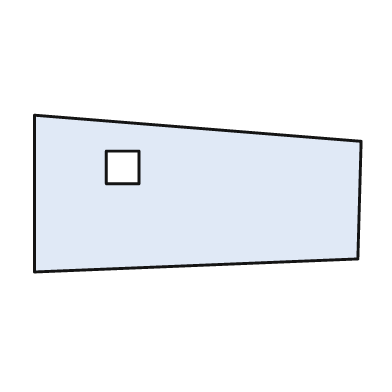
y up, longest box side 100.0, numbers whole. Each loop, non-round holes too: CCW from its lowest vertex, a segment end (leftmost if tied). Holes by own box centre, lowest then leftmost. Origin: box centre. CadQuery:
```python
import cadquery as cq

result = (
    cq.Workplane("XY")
    .moveTo(-50.0, -24.0)
    .lineTo(49.0, -20.0)
    .lineTo(50.0, 16.0)
    .lineTo(-50.0, 24.0)
    .close()
    .moveTo(-28.0, 3.0)
    .lineTo(-18.0, 3.0)
    .lineTo(-18.0, 13.0)
    .lineTo(-28.0, 13.0)
    .close()
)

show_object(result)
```